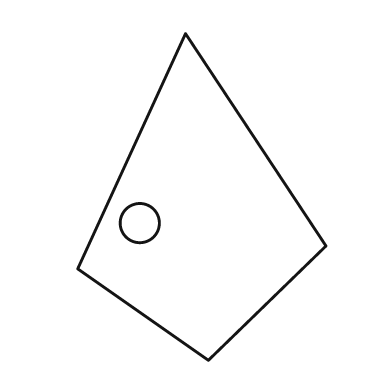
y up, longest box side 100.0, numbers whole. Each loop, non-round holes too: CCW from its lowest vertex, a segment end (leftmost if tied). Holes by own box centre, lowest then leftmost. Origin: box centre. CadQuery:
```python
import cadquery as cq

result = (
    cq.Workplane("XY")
    .moveTo(2.0, -50.0)
    .lineTo(38.0, -15.0)
    .lineTo(-5.0, 50.0)
    .lineTo(-38.0, -22.0)
    .close()
    .moveTo(-19.0, -8.0)
    .circle(6.0)
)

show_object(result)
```